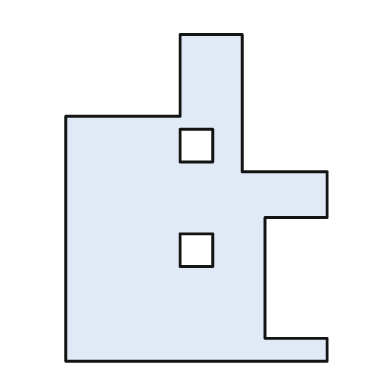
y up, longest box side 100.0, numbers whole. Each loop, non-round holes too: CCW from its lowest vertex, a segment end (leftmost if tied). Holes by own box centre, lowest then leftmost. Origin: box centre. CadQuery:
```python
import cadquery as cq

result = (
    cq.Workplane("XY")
    .moveTo(-40.0, -50.0)
    .lineTo(40.0, -50.0)
    .lineTo(40.0, -43.0)
    .lineTo(21.0, -43.0)
    .lineTo(21.0, -6.0)
    .lineTo(40.0, -6.0)
    .lineTo(40.0, 8.0)
    .lineTo(14.0, 8.0)
    .lineTo(14.0, 50.0)
    .lineTo(-5.0, 50.0)
    .lineTo(-5.0, 25.0)
    .lineTo(-40.0, 25.0)
    .close()
    .moveTo(-5.0, -21.0)
    .lineTo(5.0, -21.0)
    .lineTo(5.0, -11.0)
    .lineTo(-5.0, -11.0)
    .close()
    .moveTo(-5.0, 11.0)
    .lineTo(5.0, 11.0)
    .lineTo(5.0, 21.0)
    .lineTo(-5.0, 21.0)
    .close()
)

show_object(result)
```